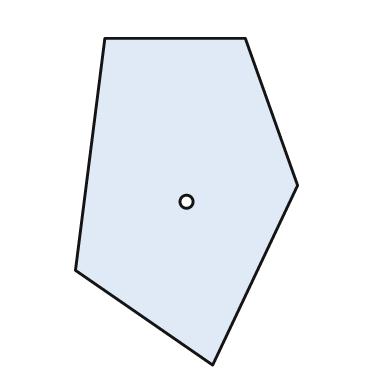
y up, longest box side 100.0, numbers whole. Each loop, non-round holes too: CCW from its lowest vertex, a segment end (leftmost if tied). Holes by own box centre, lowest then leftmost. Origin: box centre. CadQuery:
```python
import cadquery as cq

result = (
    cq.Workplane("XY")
    .moveTo(8.0, -50.0)
    .lineTo(34.0, 5.0)
    .lineTo(18.0, 50.0)
    .lineTo(-25.0, 50.0)
    .lineTo(-34.0, -21.0)
    .close()
    .moveTo(0.0, 0.0)
    .circle(2.0)
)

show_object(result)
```